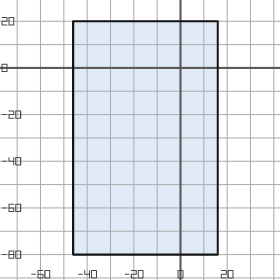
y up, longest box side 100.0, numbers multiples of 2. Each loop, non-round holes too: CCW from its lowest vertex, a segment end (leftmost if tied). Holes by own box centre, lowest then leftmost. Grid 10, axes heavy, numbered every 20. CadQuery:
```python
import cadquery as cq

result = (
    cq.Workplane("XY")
    .moveTo(-46.0, -80.0)
    .lineTo(16.0, -80.0)
    .lineTo(16.0, 20.0)
    .lineTo(-46.0, 20.0)
    .close()
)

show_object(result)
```